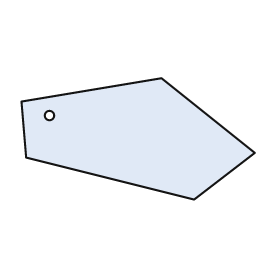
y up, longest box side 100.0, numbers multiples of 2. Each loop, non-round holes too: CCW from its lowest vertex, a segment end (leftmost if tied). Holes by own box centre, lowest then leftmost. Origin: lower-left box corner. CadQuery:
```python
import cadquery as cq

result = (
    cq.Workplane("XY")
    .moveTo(74.0, 0.0)
    .lineTo(100.0, 20.0)
    .lineTo(60.0, 52.0)
    .lineTo(0.0, 42.0)
    .lineTo(2.0, 18.0)
    .close()
    .moveTo(12.0, 36.0)
    .circle(2.0)
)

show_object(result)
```